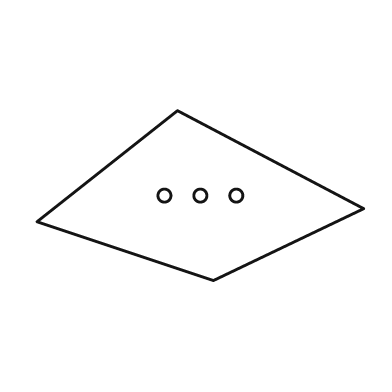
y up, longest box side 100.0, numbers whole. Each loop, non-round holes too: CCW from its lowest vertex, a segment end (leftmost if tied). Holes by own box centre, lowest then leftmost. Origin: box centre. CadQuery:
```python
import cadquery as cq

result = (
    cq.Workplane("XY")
    .moveTo(4.0, -26.0)
    .lineTo(50.0, -4.0)
    .lineTo(-7.0, 26.0)
    .lineTo(-50.0, -8.0)
    .close()
    .moveTo(-11.0, 0.0)
    .circle(2.0)
    .moveTo(0.0, 0.0)
    .circle(2.0)
    .moveTo(11.0, 0.0)
    .circle(2.0)
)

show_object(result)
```